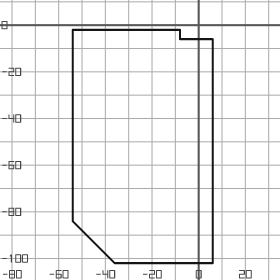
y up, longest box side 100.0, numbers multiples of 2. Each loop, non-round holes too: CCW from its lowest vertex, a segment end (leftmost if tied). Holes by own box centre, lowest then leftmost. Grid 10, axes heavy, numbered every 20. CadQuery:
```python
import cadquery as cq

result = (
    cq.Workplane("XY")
    .moveTo(-36.0, -102.0)
    .lineTo(6.0, -102.0)
    .lineTo(6.0, -6.0)
    .lineTo(-8.0, -6.0)
    .lineTo(-8.0, -2.0)
    .lineTo(-54.0, -2.0)
    .lineTo(-54.0, -84.0)
    .close()
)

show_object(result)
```